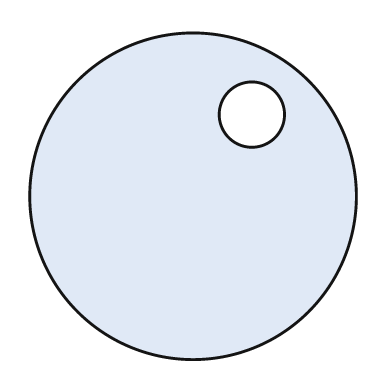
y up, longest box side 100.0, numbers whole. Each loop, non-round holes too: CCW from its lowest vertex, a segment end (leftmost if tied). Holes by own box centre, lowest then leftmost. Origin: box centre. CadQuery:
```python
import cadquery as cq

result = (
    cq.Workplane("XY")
    .moveTo(0.0, 0.0)
    .circle(50.0)
    .moveTo(18.0, 25.0)
    .circle(10.0)
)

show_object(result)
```